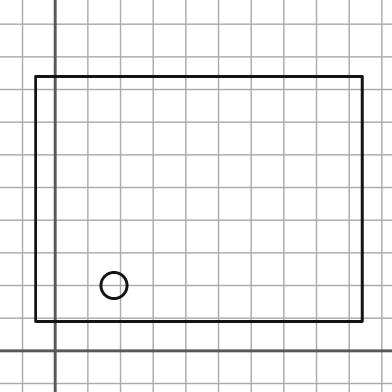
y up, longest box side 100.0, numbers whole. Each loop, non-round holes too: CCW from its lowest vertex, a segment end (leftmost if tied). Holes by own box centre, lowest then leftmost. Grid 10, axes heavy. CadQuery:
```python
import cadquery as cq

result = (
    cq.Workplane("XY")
    .moveTo(-6.0, 9.0)
    .lineTo(94.0, 9.0)
    .lineTo(94.0, 84.0)
    .lineTo(-6.0, 84.0)
    .close()
    .moveTo(18.0, 20.0)
    .circle(4.0)
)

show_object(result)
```